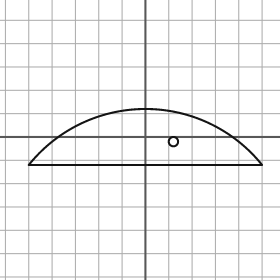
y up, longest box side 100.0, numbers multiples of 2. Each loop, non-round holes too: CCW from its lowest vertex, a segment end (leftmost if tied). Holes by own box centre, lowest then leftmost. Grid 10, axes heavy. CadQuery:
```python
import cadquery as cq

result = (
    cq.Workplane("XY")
    .moveTo(-50.0, -12.0)
    .lineTo(50.0, -12.0)
    .threePointArc((0.0, 12.0), (-50.0, -12.0))
    .close()
    .moveTo(12.0, -2.0)
    .circle(2.0)
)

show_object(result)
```